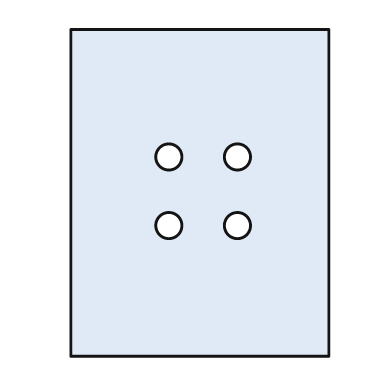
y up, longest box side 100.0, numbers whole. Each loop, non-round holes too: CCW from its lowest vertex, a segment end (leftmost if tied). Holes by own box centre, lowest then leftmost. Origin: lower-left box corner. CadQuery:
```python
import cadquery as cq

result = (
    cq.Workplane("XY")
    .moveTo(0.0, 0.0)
    .lineTo(79.0, 0.0)
    .lineTo(79.0, 100.0)
    .lineTo(0.0, 100.0)
    .close()
    .moveTo(30.0, 40.0)
    .circle(4.0)
    .moveTo(51.0, 40.0)
    .circle(4.0)
    .moveTo(30.0, 61.0)
    .circle(4.0)
    .moveTo(51.0, 61.0)
    .circle(4.0)
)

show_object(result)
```